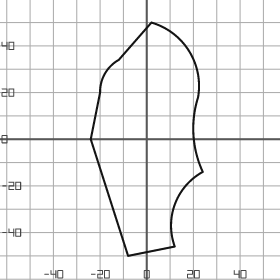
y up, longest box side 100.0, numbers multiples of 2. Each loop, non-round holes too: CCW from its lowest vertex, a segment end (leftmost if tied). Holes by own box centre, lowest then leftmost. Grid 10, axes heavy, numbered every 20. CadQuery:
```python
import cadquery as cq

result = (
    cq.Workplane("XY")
    .moveTo(-8.0, -50.0)
    .lineTo(12.0, -46.0)
    .threePointArc((12.0, -28.0), (24.0, -14.0))
    .threePointArc((20.0, 2.0), (22.0, 18.0))
    .threePointArc((18.0, 38.0), (2.0, 50.0))
    .lineTo(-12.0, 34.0)
    .threePointArc((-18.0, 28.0), (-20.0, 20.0))
    .lineTo(-24.0, 0.0)
    .close()
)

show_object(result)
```